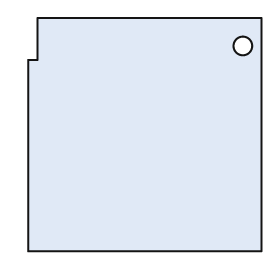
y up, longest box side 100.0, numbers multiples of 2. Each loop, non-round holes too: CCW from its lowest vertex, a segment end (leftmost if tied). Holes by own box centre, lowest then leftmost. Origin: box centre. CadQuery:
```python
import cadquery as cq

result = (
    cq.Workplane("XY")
    .moveTo(-50.0, -50.0)
    .lineTo(50.0, -50.0)
    .lineTo(50.0, 50.0)
    .lineTo(-46.0, 50.0)
    .lineTo(-46.0, 32.0)
    .lineTo(-50.0, 32.0)
    .close()
    .moveTo(42.0, 38.0)
    .circle(4.0)
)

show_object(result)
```